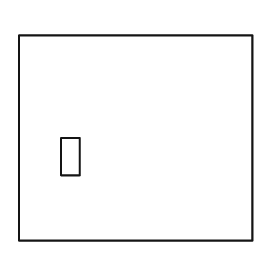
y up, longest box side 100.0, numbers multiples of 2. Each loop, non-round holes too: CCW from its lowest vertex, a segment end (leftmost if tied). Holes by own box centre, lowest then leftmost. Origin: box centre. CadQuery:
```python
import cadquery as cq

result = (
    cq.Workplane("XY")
    .moveTo(-50.0, -44.0)
    .lineTo(50.0, -44.0)
    .lineTo(50.0, 44.0)
    .lineTo(-50.0, 44.0)
    .close()
    .moveTo(-32.0, -16.0)
    .lineTo(-24.0, -16.0)
    .lineTo(-24.0, 0.0)
    .lineTo(-32.0, 0.0)
    .close()
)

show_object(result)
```